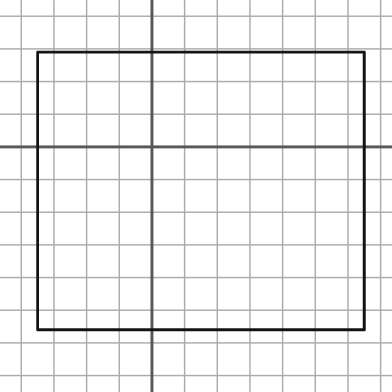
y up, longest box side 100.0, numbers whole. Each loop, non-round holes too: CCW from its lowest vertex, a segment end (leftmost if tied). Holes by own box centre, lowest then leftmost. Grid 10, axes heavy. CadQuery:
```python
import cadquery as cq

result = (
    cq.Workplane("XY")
    .moveTo(-35.0, -56.0)
    .lineTo(65.0, -56.0)
    .lineTo(65.0, 29.0)
    .lineTo(-35.0, 29.0)
    .close()
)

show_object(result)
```